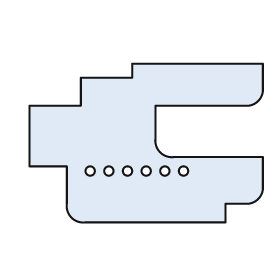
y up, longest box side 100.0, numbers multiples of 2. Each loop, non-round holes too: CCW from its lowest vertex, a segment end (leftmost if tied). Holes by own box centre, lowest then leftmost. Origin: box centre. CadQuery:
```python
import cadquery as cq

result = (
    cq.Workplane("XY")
    .moveTo(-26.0, -34.0)
    .lineTo(34.0, -34.0)
    .lineTo(34.0, -26.0)
    .lineTo(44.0, -26.0)
    .threePointArc((48.0, -24.0), (50.0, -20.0))
    .lineTo(50.0, -6.0)
    .lineTo(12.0, -6.0)
    .threePointArc((6.0, -4.0), (4.0, 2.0))
    .lineTo(4.0, 16.0)
    .lineTo(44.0, 16.0)
    .threePointArc((48.0, 18.0), (50.0, 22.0))
    .lineTo(50.0, 34.0)
    .lineTo(-6.0, 34.0)
    .lineTo(-6.0, 28.0)
    .lineTo(-28.0, 28.0)
    .lineTo(-28.0, 16.0)
    .lineTo(-50.0, 16.0)
    .lineTo(-50.0, -10.0)
    .lineTo(-34.0, -10.0)
    .lineTo(-34.0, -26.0)
    .threePointArc((-32.0, -32.0), (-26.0, -34.0))
    .close()
    .moveTo(-24.0, -12.0)
    .circle(2.0)
    .moveTo(-16.0, -12.0)
    .circle(2.0)
    .moveTo(-8.0, -12.0)
    .circle(2.0)
    .moveTo(0.0, -12.0)
    .circle(2.0)
    .moveTo(8.0, -12.0)
    .circle(2.0)
    .moveTo(16.0, -12.0)
    .circle(2.0)
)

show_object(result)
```